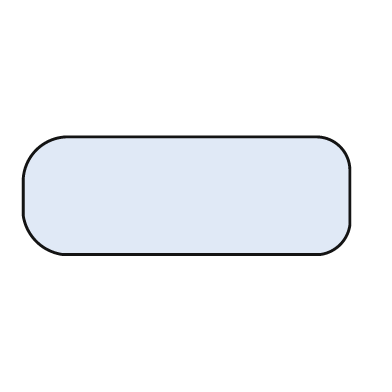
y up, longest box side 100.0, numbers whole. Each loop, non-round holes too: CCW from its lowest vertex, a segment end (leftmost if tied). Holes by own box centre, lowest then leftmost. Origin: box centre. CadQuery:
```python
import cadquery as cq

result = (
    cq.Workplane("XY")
    .moveTo(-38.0, -18.0)
    .lineTo(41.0, -18.0)
    .threePointArc((47.0, -15.0), (50.0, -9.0))
    .lineTo(50.0, 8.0)
    .threePointArc((47.0, 15.0), (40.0, 18.0))
    .lineTo(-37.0, 18.0)
    .threePointArc((-46.0, 14.0), (-50.0, 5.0))
    .lineTo(-50.0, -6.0)
    .threePointArc((-46.0, -14.0), (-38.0, -18.0))
    .close()
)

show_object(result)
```